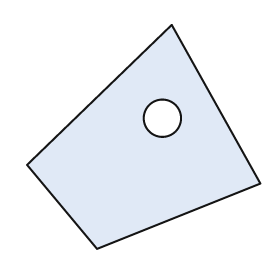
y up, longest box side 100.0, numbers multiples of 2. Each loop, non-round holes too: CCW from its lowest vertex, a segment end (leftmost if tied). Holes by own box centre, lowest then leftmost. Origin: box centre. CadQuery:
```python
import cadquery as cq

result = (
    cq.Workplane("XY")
    .moveTo(-20.0, -48.0)
    .lineTo(50.0, -20.0)
    .lineTo(12.0, 48.0)
    .lineTo(-50.0, -12.0)
    .close()
    .moveTo(8.0, 8.0)
    .circle(8.0)
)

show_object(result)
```